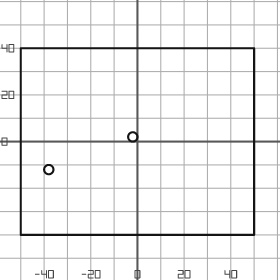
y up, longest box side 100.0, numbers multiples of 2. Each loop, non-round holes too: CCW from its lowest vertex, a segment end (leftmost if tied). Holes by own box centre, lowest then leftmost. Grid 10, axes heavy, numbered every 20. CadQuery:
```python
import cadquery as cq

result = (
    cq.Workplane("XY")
    .moveTo(-50.0, -40.0)
    .lineTo(50.0, -40.0)
    .lineTo(50.0, 40.0)
    .lineTo(-50.0, 40.0)
    .close()
    .moveTo(-38.0, -12.0)
    .circle(2.0)
    .moveTo(-2.0, 2.0)
    .circle(2.0)
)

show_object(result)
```